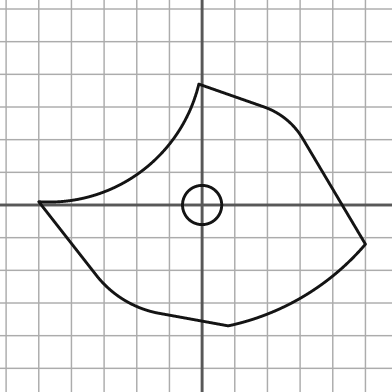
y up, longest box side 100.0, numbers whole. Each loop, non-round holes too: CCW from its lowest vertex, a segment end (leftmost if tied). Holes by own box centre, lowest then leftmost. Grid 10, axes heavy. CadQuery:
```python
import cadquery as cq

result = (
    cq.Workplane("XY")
    .moveTo(8.0, -37.0)
    .threePointArc((31.0, -28.0), (50.0, -12.0))
    .lineTo(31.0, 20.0)
    .threePointArc((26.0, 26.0), (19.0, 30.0))
    .lineTo(-1.0, 37.0)
    .threePointArc((-19.0, 10.0), (-50.0, 1.0))
    .lineTo(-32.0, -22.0)
    .threePointArc((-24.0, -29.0), (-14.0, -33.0))
    .close()
    .moveTo(0.0, 0.0)
    .circle(6.0)
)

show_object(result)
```